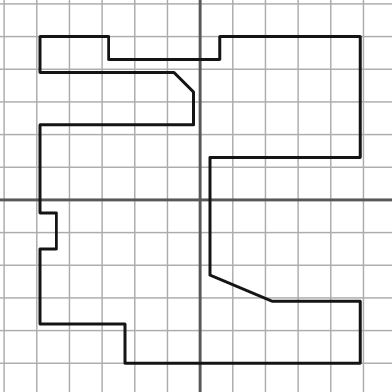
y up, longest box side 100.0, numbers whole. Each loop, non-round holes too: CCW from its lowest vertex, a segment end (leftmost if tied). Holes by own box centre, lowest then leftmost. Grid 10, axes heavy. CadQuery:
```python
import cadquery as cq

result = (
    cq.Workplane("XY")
    .moveTo(-23.0, -50.0)
    .lineTo(49.0, -50.0)
    .lineTo(49.0, -31.0)
    .lineTo(22.0, -31.0)
    .lineTo(3.0, -23.0)
    .lineTo(3.0, 13.0)
    .lineTo(49.0, 13.0)
    .lineTo(49.0, 50.0)
    .lineTo(6.0, 50.0)
    .lineTo(6.0, 43.0)
    .lineTo(-28.0, 43.0)
    .lineTo(-28.0, 50.0)
    .lineTo(-49.0, 50.0)
    .lineTo(-49.0, 39.0)
    .lineTo(-8.0, 39.0)
    .lineTo(-2.0, 33.0)
    .lineTo(-2.0, 23.0)
    .lineTo(-49.0, 23.0)
    .lineTo(-49.0, -4.0)
    .lineTo(-44.0, -4.0)
    .lineTo(-44.0, -15.0)
    .lineTo(-49.0, -15.0)
    .lineTo(-49.0, -38.0)
    .lineTo(-23.0, -38.0)
    .close()
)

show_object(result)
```